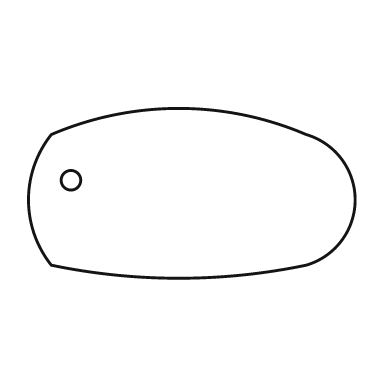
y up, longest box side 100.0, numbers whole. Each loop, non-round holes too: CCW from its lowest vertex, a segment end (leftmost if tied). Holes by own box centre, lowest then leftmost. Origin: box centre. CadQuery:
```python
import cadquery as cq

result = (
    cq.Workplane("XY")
    .moveTo(-43.0, -22.0)
    .threePointArc((-4.0, -26.0), (35.0, -22.0))
    .threePointArc((50.0, -2.0), (35.0, 18.0))
    .threePointArc((-4.0, 26.0), (-43.0, 18.0))
    .threePointArc((-50.0, -2.0), (-43.0, -22.0))
    .close()
    .moveTo(-37.0, 4.0)
    .circle(3.0)
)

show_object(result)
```